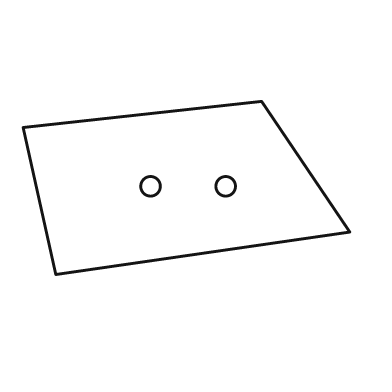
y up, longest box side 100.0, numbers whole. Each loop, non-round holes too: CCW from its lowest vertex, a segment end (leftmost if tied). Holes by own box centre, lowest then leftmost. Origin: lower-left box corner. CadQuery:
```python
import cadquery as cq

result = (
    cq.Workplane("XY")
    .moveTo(10.0, 0.0)
    .lineTo(100.0, 13.0)
    .lineTo(73.0, 53.0)
    .lineTo(0.0, 45.0)
    .close()
    .moveTo(39.0, 27.0)
    .circle(3.0)
    .moveTo(62.0, 27.0)
    .circle(3.0)
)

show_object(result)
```